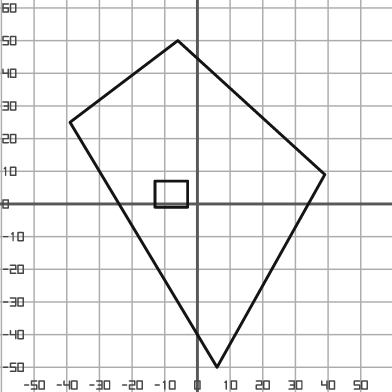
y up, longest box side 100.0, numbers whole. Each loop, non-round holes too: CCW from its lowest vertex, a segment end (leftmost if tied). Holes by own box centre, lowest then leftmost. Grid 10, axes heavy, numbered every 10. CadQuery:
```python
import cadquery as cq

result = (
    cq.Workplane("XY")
    .moveTo(6.0, -50.0)
    .lineTo(39.0, 9.0)
    .lineTo(-6.0, 50.0)
    .lineTo(-39.0, 25.0)
    .close()
    .moveTo(-13.0, -1.0)
    .lineTo(-3.0, -1.0)
    .lineTo(-3.0, 7.0)
    .lineTo(-13.0, 7.0)
    .close()
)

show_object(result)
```